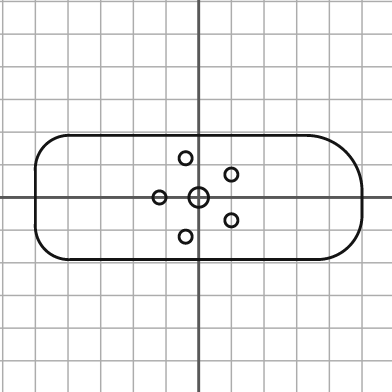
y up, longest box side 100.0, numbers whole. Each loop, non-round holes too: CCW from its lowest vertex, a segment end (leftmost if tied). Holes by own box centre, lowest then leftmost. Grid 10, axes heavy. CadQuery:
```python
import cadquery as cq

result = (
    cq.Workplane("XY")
    .moveTo(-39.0, -19.0)
    .lineTo(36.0, -19.0)
    .threePointArc((46.0, -15.0), (50.0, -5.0))
    .lineTo(50.0, 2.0)
    .threePointArc((45.0, 14.0), (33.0, 19.0))
    .lineTo(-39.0, 19.0)
    .threePointArc((-47.0, 16.0), (-50.0, 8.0))
    .lineTo(-50.0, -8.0)
    .threePointArc((-47.0, -16.0), (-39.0, -19.0))
    .close()
    .moveTo(-4.0, -12.0)
    .circle(2.0)
    .moveTo(10.0, -7.0)
    .circle(2.0)
    .moveTo(-12.0, 0.0)
    .circle(2.0)
    .moveTo(0.0, 0.0)
    .circle(3.0)
    .moveTo(10.0, 7.0)
    .circle(2.0)
    .moveTo(-4.0, 12.0)
    .circle(2.0)
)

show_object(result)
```